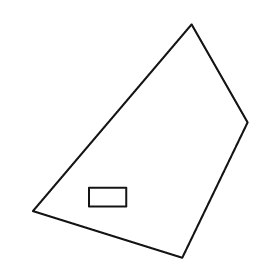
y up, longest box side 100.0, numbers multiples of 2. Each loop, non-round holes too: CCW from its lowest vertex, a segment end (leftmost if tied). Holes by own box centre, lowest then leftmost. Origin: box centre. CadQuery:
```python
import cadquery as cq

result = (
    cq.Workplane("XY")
    .moveTo(18.0, -50.0)
    .lineTo(46.0, 8.0)
    .lineTo(22.0, 50.0)
    .lineTo(-46.0, -30.0)
    .close()
    .moveTo(-22.0, -28.0)
    .lineTo(-6.0, -28.0)
    .lineTo(-6.0, -20.0)
    .lineTo(-22.0, -20.0)
    .close()
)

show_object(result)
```